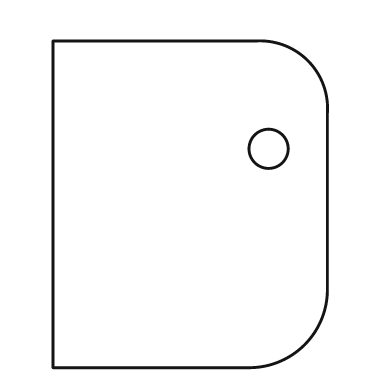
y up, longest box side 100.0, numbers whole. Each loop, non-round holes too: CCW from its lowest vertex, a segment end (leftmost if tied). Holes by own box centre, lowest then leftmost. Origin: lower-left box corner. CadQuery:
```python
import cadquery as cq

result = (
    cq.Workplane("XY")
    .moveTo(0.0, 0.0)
    .lineTo(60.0, 0.0)
    .threePointArc((77.0, 7.0), (84.0, 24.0))
    .lineTo(84.0, 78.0)
    .threePointArc((78.0, 94.0), (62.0, 100.0))
    .lineTo(0.0, 100.0)
    .close()
    .moveTo(66.0, 67.0)
    .circle(6.0)
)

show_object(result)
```